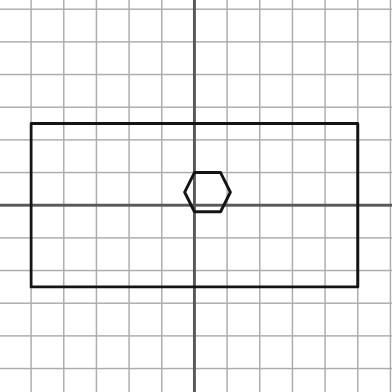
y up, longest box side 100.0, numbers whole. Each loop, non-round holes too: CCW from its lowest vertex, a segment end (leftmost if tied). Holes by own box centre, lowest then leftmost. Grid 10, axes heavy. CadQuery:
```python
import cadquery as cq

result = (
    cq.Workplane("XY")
    .moveTo(-50.0, -25.0)
    .lineTo(50.0, -25.0)
    .lineTo(50.0, 25.0)
    .lineTo(-50.0, 25.0)
    .close()
    .moveTo(0.0, -2.0)
    .lineTo(8.0, -2.0)
    .lineTo(11.0, 4.0)
    .lineTo(8.0, 10.0)
    .lineTo(0.0, 10.0)
    .lineTo(-3.0, 4.0)
    .close()
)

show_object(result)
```